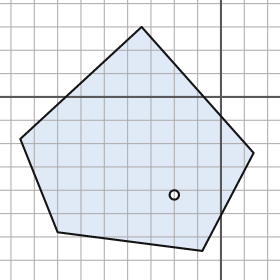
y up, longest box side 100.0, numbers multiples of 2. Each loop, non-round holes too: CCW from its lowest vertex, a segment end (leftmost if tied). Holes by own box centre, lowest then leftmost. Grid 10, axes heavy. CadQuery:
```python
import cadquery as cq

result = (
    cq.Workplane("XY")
    .moveTo(-8.0, -66.0)
    .lineTo(14.0, -24.0)
    .lineTo(-34.0, 30.0)
    .lineTo(-86.0, -18.0)
    .lineTo(-70.0, -58.0)
    .close()
    .moveTo(-20.0, -42.0)
    .circle(2.0)
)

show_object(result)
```